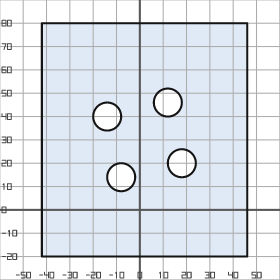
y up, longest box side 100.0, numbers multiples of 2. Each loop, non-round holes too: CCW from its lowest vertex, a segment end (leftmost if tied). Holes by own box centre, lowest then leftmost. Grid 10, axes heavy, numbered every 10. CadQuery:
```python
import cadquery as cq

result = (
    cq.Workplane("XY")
    .moveTo(-42.0, -20.0)
    .lineTo(46.0, -20.0)
    .lineTo(46.0, 80.0)
    .lineTo(-42.0, 80.0)
    .close()
    .moveTo(-8.0, 14.0)
    .circle(6.0)
    .moveTo(18.0, 20.0)
    .circle(6.0)
    .moveTo(-14.0, 40.0)
    .circle(6.0)
    .moveTo(12.0, 46.0)
    .circle(6.0)
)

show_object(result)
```